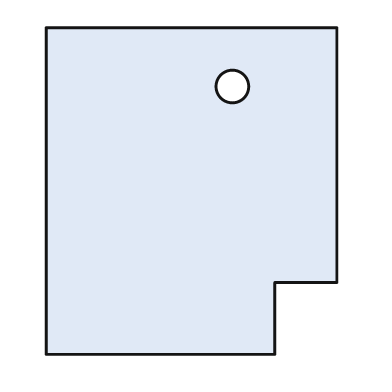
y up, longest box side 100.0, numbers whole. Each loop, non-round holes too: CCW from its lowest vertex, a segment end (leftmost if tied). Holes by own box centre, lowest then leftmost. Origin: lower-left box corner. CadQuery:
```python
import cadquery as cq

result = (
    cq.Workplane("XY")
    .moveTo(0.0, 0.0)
    .lineTo(70.0, 0.0)
    .lineTo(70.0, 22.0)
    .lineTo(89.0, 22.0)
    .lineTo(89.0, 100.0)
    .lineTo(0.0, 100.0)
    .close()
    .moveTo(57.0, 82.0)
    .circle(5.0)
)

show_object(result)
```